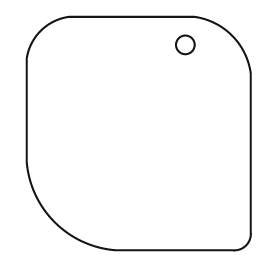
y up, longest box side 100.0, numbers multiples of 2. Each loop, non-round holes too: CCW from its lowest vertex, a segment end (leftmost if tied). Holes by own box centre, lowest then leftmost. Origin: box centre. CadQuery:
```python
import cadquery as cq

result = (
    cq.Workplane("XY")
    .moveTo(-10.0, -50.0)
    .lineTo(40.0, -50.0)
    .threePointArc((46.0, -48.0), (48.0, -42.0))
    .lineTo(48.0, 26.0)
    .threePointArc((40.0, 42.0), (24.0, 50.0))
    .lineTo(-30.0, 50.0)
    .threePointArc((-42.0, 44.0), (-48.0, 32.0))
    .lineTo(-48.0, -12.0)
    .threePointArc((-36.0, -38.0), (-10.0, -50.0))
    .close()
    .moveTo(20.0, 38.0)
    .circle(4.0)
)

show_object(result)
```